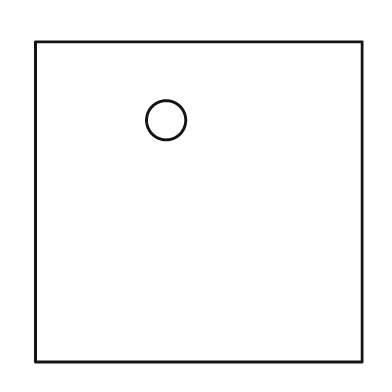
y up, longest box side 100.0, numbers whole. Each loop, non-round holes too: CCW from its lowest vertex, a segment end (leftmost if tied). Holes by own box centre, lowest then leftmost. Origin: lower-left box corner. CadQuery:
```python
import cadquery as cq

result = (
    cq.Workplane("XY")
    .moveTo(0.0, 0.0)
    .lineTo(100.0, 0.0)
    .lineTo(100.0, 98.0)
    .lineTo(0.0, 98.0)
    .close()
    .moveTo(40.0, 74.0)
    .circle(6.0)
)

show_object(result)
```